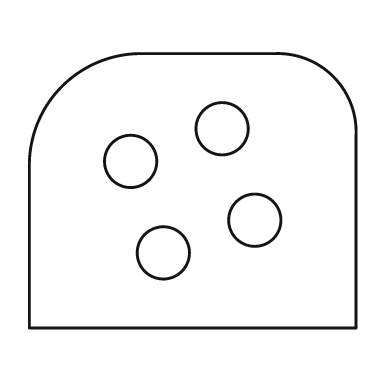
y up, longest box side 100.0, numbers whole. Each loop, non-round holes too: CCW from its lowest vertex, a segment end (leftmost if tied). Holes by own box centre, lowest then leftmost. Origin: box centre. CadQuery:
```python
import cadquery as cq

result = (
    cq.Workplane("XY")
    .moveTo(-50.0, -42.0)
    .lineTo(50.0, -42.0)
    .lineTo(50.0, 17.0)
    .threePointArc((43.0, 35.0), (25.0, 42.0))
    .lineTo(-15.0, 42.0)
    .threePointArc((-40.0, 32.0), (-50.0, 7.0))
    .close()
    .moveTo(-9.0, -19.0)
    .circle(8.0)
    .moveTo(19.0, -9.0)
    .circle(8.0)
    .moveTo(-19.0, 9.0)
    .circle(8.0)
    .moveTo(9.0, 19.0)
    .circle(8.0)
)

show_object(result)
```